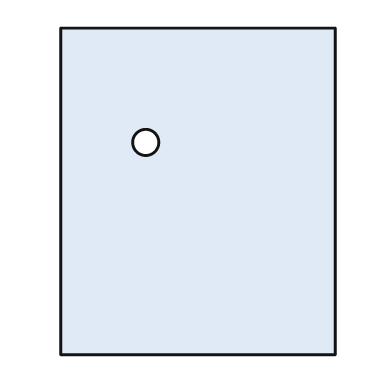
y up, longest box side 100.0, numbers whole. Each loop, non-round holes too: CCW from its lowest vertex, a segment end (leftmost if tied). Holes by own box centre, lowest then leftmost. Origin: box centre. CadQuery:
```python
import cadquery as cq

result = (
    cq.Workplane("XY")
    .moveTo(-42.0, -50.0)
    .lineTo(42.0, -50.0)
    .lineTo(42.0, 50.0)
    .lineTo(-42.0, 50.0)
    .close()
    .moveTo(-16.0, 15.0)
    .circle(4.0)
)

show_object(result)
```